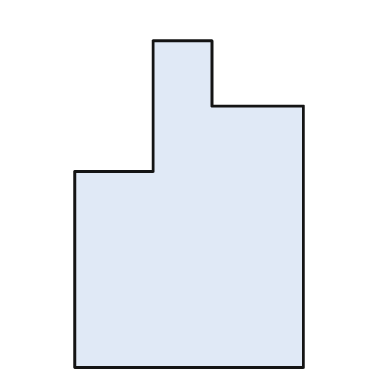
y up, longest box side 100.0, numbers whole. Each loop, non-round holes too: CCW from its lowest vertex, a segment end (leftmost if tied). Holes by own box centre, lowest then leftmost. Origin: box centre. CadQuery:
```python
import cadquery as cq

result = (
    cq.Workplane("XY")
    .moveTo(-35.0, -50.0)
    .lineTo(35.0, -50.0)
    .lineTo(35.0, 30.0)
    .lineTo(7.0, 30.0)
    .lineTo(7.0, 50.0)
    .lineTo(-11.0, 50.0)
    .lineTo(-11.0, 10.0)
    .lineTo(-35.0, 10.0)
    .close()
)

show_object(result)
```